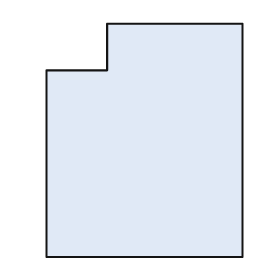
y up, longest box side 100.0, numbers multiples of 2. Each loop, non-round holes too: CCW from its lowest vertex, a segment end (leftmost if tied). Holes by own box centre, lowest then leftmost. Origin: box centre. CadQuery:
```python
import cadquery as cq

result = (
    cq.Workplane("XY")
    .moveTo(-42.0, -50.0)
    .lineTo(42.0, -50.0)
    .lineTo(42.0, 50.0)
    .lineTo(-16.0, 50.0)
    .lineTo(-16.0, 30.0)
    .lineTo(-42.0, 30.0)
    .close()
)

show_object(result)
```